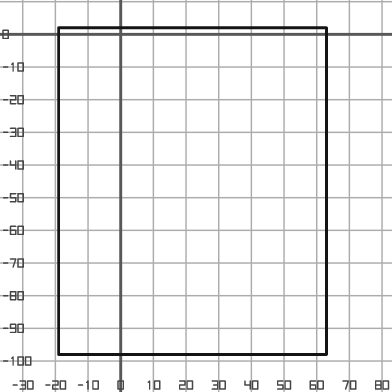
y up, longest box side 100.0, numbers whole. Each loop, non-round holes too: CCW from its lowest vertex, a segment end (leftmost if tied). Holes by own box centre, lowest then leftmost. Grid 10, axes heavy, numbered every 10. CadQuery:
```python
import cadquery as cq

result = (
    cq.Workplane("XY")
    .moveTo(-19.0, -98.0)
    .lineTo(63.0, -98.0)
    .lineTo(63.0, 2.0)
    .lineTo(-19.0, 2.0)
    .close()
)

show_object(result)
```